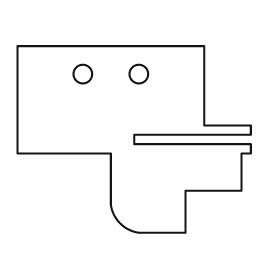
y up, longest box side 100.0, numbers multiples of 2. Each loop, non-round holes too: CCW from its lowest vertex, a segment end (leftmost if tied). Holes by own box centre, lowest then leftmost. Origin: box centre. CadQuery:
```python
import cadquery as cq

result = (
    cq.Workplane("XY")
    .moveTo(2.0, -40.0)
    .lineTo(22.0, -40.0)
    .lineTo(22.0, -22.0)
    .lineTo(46.0, -22.0)
    .lineTo(46.0, -6.0)
    .lineTo(50.0, -6.0)
    .lineTo(50.0, -2.0)
    .lineTo(0.0, -2.0)
    .lineTo(0.0, 2.0)
    .lineTo(50.0, 2.0)
    .lineTo(50.0, 6.0)
    .lineTo(30.0, 6.0)
    .lineTo(30.0, 40.0)
    .lineTo(-50.0, 40.0)
    .lineTo(-50.0, -6.0)
    .lineTo(-10.0, -6.0)
    .lineTo(-10.0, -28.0)
    .threePointArc((-6.0, -36.0), (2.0, -40.0))
    .close()
    .moveTo(-22.0, 28.0)
    .circle(4.0)
    .moveTo(2.0, 28.0)
    .circle(4.0)
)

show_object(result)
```